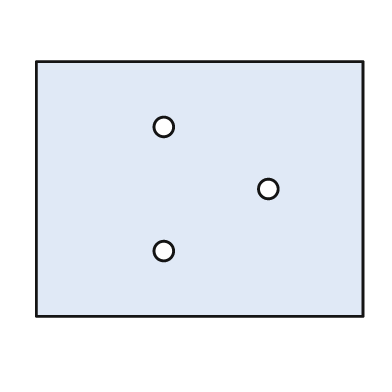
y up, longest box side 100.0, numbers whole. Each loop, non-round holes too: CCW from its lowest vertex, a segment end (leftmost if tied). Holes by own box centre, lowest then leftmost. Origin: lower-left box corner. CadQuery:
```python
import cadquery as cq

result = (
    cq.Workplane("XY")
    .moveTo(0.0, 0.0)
    .lineTo(100.0, 0.0)
    .lineTo(100.0, 78.0)
    .lineTo(0.0, 78.0)
    .close()
    .moveTo(39.0, 20.0)
    .circle(3.0)
    .moveTo(71.0, 39.0)
    .circle(3.0)
    .moveTo(39.0, 58.0)
    .circle(3.0)
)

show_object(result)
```